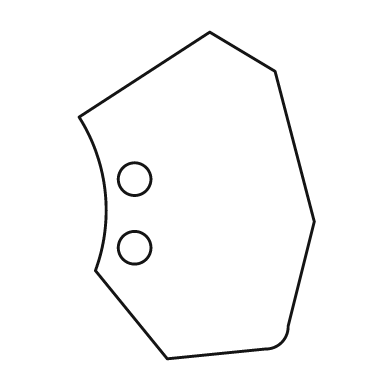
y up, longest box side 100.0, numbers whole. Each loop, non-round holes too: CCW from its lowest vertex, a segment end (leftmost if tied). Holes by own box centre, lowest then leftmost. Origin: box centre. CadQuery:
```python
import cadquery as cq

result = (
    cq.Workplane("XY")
    .moveTo(-9.0, -50.0)
    .lineTo(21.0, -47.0)
    .threePointArc((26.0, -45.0), (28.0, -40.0))
    .lineTo(36.0, -8.0)
    .lineTo(24.0, 38.0)
    .lineTo(4.0, 50.0)
    .lineTo(-36.0, 24.0)
    .threePointArc((-28.0, 1.0), (-31.0, -23.0))
    .close()
    .moveTo(-19.0, -16.0)
    .circle(5.0)
    .moveTo(-19.0, 5.0)
    .circle(5.0)
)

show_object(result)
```